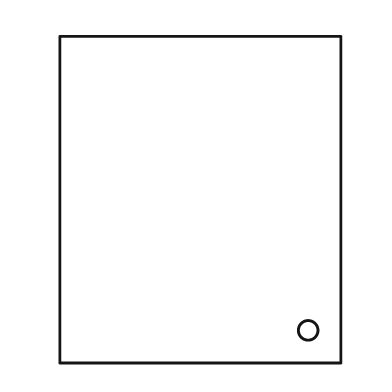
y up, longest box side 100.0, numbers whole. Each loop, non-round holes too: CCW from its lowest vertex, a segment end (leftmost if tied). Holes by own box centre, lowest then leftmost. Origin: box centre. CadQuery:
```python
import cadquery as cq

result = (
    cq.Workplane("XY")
    .moveTo(-43.0, -50.0)
    .lineTo(43.0, -50.0)
    .lineTo(43.0, 50.0)
    .lineTo(-43.0, 50.0)
    .close()
    .moveTo(33.0, -40.0)
    .circle(3.0)
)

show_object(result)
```